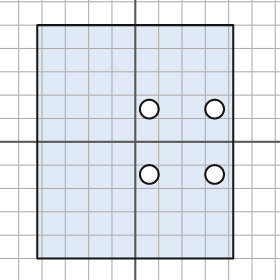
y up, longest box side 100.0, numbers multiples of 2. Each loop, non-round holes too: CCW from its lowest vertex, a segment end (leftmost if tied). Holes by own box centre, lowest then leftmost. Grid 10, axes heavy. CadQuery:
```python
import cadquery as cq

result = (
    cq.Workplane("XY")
    .moveTo(-42.0, -50.0)
    .lineTo(42.0, -50.0)
    .lineTo(42.0, 50.0)
    .lineTo(-42.0, 50.0)
    .close()
    .moveTo(6.0, -14.0)
    .circle(4.0)
    .moveTo(34.0, -14.0)
    .circle(4.0)
    .moveTo(6.0, 14.0)
    .circle(4.0)
    .moveTo(34.0, 14.0)
    .circle(4.0)
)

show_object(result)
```